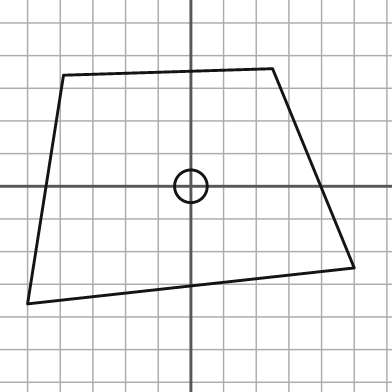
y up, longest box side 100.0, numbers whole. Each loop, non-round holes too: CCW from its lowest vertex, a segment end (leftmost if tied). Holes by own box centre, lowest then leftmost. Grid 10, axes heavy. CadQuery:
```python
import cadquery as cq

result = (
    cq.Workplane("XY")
    .moveTo(-50.0, -36.0)
    .lineTo(50.0, -25.0)
    .lineTo(25.0, 36.0)
    .lineTo(-39.0, 34.0)
    .close()
    .moveTo(0.0, 0.0)
    .circle(5.0)
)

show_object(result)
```